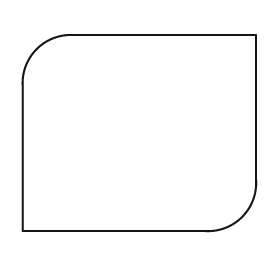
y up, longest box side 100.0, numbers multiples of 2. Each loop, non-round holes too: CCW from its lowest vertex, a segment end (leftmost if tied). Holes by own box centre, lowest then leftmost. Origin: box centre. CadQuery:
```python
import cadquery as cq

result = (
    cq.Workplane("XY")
    .moveTo(-50.0, -42.0)
    .lineTo(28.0, -42.0)
    .threePointArc((44.0, -36.0), (50.0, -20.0))
    .lineTo(50.0, 42.0)
    .lineTo(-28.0, 42.0)
    .threePointArc((-44.0, 36.0), (-50.0, 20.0))
    .close()
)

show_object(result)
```